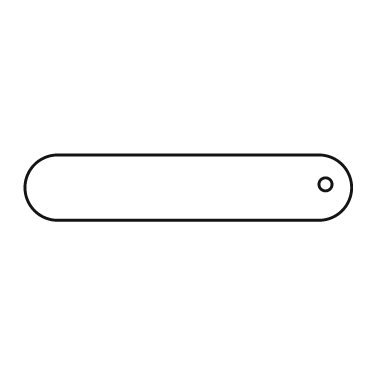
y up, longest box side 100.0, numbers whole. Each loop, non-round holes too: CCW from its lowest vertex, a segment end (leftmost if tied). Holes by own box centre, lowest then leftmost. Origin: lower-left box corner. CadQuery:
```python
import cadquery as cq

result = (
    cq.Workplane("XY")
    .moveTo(10.0, 0.0)
    .lineTo(90.0, 0.0)
    .threePointArc((100.0, 10.0), (90.0, 20.0))
    .lineTo(10.0, 20.0)
    .threePointArc((0.0, 10.0), (10.0, 0.0))
    .close()
    .moveTo(92.0, 11.0)
    .circle(2.0)
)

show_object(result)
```